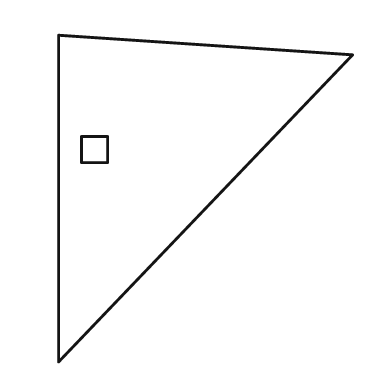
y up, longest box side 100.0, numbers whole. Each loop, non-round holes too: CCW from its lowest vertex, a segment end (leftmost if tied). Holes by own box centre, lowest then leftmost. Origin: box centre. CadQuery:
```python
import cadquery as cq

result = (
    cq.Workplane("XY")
    .moveTo(-45.0, -50.0)
    .lineTo(45.0, 44.0)
    .lineTo(-45.0, 50.0)
    .close()
    .moveTo(-38.0, 11.0)
    .lineTo(-30.0, 11.0)
    .lineTo(-30.0, 19.0)
    .lineTo(-38.0, 19.0)
    .close()
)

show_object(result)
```